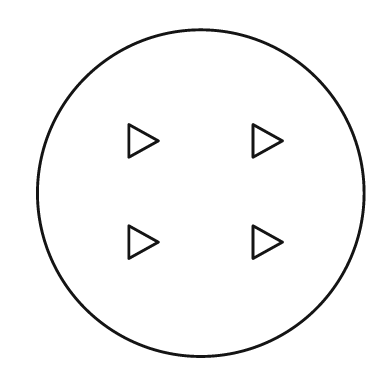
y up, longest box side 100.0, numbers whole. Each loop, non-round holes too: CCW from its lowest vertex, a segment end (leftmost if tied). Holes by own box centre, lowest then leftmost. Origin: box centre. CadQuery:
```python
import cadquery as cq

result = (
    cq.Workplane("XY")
    .moveTo(0.0, 0.0)
    .circle(50.0)
    .moveTo(-22.0, -20.0)
    .lineTo(-13.0, -15.0)
    .lineTo(-22.0, -10.0)
    .close()
    .moveTo(16.0, -20.0)
    .lineTo(25.0, -15.0)
    .lineTo(16.0, -10.0)
    .close()
    .moveTo(-22.0, 11.0)
    .lineTo(-13.0, 16.0)
    .lineTo(-22.0, 21.0)
    .close()
    .moveTo(16.0, 11.0)
    .lineTo(25.0, 16.0)
    .lineTo(16.0, 21.0)
    .close()
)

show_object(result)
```